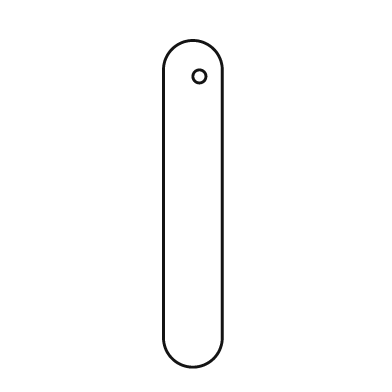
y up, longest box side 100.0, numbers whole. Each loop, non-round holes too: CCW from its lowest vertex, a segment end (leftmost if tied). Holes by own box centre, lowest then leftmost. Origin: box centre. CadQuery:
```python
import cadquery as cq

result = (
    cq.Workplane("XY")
    .moveTo(-9.0, -41.0)
    .threePointArc((0.0, -50.0), (9.0, -41.0))
    .lineTo(9.0, 41.0)
    .threePointArc((0.0, 50.0), (-9.0, 41.0))
    .close()
    .moveTo(2.0, 39.0)
    .circle(2.0)
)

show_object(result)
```